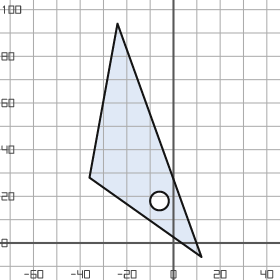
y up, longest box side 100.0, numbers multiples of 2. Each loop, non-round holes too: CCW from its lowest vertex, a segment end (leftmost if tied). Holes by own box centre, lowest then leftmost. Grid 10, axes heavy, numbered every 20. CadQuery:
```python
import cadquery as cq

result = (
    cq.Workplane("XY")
    .moveTo(12.0, -6.0)
    .lineTo(-24.0, 94.0)
    .lineTo(-36.0, 28.0)
    .close()
    .moveTo(-6.0, 18.0)
    .circle(4.0)
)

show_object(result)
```